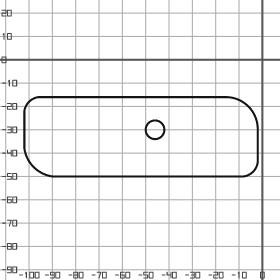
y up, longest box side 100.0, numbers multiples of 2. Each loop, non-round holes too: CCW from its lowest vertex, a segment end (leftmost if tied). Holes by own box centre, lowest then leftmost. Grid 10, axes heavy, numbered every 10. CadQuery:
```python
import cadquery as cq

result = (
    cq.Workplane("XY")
    .moveTo(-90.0, -50.0)
    .lineTo(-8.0, -50.0)
    .threePointArc((-4.0, -48.0), (-2.0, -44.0))
    .lineTo(-2.0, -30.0)
    .threePointArc((-6.0, -20.0), (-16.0, -16.0))
    .lineTo(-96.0, -16.0)
    .threePointArc((-100.0, -18.0), (-102.0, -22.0))
    .lineTo(-102.0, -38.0)
    .threePointArc((-98.0, -46.0), (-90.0, -50.0))
    .close()
    .moveTo(-46.0, -30.0)
    .circle(4.0)
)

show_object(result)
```